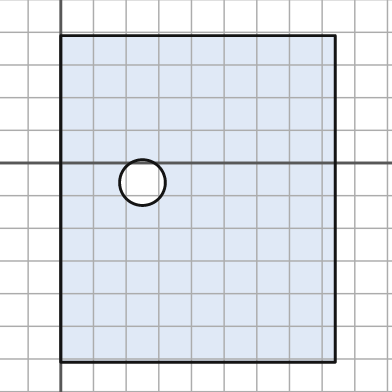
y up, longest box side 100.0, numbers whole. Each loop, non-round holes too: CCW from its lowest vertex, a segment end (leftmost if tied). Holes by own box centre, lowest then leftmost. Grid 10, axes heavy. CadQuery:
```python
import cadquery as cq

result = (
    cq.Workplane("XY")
    .moveTo(0.0, -61.0)
    .lineTo(84.0, -61.0)
    .lineTo(84.0, 39.0)
    .lineTo(0.0, 39.0)
    .close()
    .moveTo(25.0, -6.0)
    .circle(7.0)
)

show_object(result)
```